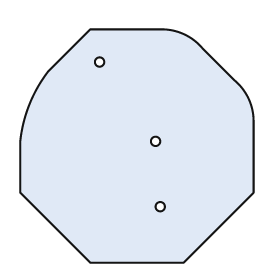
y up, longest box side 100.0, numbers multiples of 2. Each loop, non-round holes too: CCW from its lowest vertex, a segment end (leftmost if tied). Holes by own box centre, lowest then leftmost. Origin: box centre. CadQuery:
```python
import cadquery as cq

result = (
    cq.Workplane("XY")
    .moveTo(-20.0, -50.0)
    .lineTo(20.0, -50.0)
    .lineTo(50.0, -20.0)
    .lineTo(50.0, 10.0)
    .threePointArc((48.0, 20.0), (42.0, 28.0))
    .lineTo(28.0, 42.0)
    .threePointArc((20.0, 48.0), (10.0, 50.0))
    .lineTo(-20.0, 50.0)
    .lineTo(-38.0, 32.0)
    .threePointArc((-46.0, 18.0), (-50.0, 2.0))
    .lineTo(-50.0, -20.0)
    .close()
    .moveTo(10.0, -26.0)
    .circle(2.0)
    .moveTo(8.0, 2.0)
    .circle(2.0)
    .moveTo(-16.0, 36.0)
    .circle(2.0)
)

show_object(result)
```